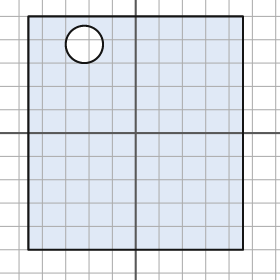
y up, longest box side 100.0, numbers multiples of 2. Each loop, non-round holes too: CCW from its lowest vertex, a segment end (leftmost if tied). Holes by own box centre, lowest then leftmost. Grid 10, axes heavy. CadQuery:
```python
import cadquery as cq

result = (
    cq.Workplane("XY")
    .moveTo(-46.0, -50.0)
    .lineTo(46.0, -50.0)
    .lineTo(46.0, 50.0)
    .lineTo(-46.0, 50.0)
    .close()
    .moveTo(-22.0, 38.0)
    .circle(8.0)
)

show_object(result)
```